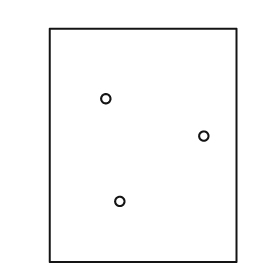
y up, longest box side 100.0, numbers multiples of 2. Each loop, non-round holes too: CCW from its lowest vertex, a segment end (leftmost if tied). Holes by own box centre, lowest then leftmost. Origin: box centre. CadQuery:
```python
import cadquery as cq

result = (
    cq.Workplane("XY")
    .moveTo(-40.0, -50.0)
    .lineTo(40.0, -50.0)
    .lineTo(40.0, 50.0)
    .lineTo(-40.0, 50.0)
    .close()
    .moveTo(-10.0, -24.0)
    .circle(2.0)
    .moveTo(26.0, 4.0)
    .circle(2.0)
    .moveTo(-16.0, 20.0)
    .circle(2.0)
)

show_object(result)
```